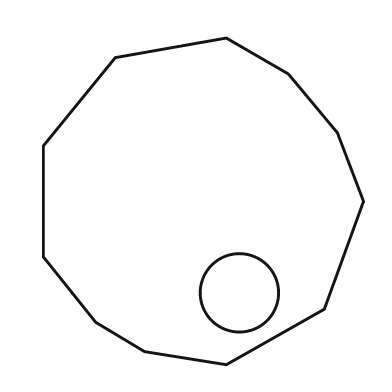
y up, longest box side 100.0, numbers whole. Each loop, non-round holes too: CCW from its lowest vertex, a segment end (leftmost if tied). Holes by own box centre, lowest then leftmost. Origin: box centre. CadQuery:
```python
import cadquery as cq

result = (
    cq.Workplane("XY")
    .moveTo(7.0, -50.0)
    .lineTo(37.0, -33.0)
    .lineTo(49.0, 0.0)
    .lineTo(41.0, 21.0)
    .lineTo(26.0, 39.0)
    .lineTo(7.0, 50.0)
    .lineTo(-27.0, 44.0)
    .lineTo(-49.0, 17.0)
    .lineTo(-49.0, -17.0)
    .lineTo(-33.0, -37.0)
    .lineTo(-18.0, -46.0)
    .close()
    .moveTo(11.0, -28.0)
    .circle(12.0)
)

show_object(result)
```